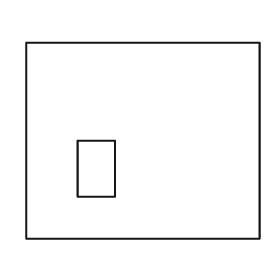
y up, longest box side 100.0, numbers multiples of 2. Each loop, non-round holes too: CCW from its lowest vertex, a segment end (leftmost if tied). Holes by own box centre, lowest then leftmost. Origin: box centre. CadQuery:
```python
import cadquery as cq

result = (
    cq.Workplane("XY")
    .moveTo(-50.0, -42.0)
    .lineTo(50.0, -42.0)
    .lineTo(50.0, 42.0)
    .lineTo(-50.0, 42.0)
    .close()
    .moveTo(-28.0, -24.0)
    .lineTo(-12.0, -24.0)
    .lineTo(-12.0, 0.0)
    .lineTo(-28.0, 0.0)
    .close()
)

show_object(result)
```